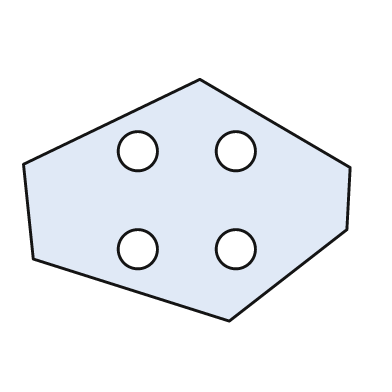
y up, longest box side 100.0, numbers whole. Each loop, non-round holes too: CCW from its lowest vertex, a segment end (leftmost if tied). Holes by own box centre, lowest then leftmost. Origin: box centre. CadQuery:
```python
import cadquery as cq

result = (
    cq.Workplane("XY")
    .moveTo(13.0, -37.0)
    .lineTo(49.0, -9.0)
    .lineTo(50.0, 10.0)
    .lineTo(4.0, 37.0)
    .lineTo(-50.0, 11.0)
    .lineTo(-47.0, -18.0)
    .close()
    .moveTo(-15.0, -15.0)
    .circle(6.0)
    .moveTo(15.0, -15.0)
    .circle(6.0)
    .moveTo(-15.0, 15.0)
    .circle(6.0)
    .moveTo(15.0, 15.0)
    .circle(6.0)
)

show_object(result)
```